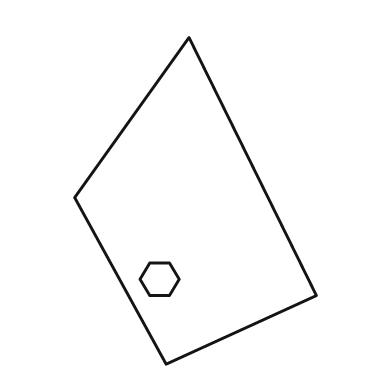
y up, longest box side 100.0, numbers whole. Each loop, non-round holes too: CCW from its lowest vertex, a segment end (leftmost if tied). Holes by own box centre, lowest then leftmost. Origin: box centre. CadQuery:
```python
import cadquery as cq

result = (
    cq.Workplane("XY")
    .moveTo(-9.0, -50.0)
    .lineTo(37.0, -29.0)
    .lineTo(-2.0, 50.0)
    .lineTo(-37.0, 1.0)
    .close()
    .moveTo(-14.0, -29.0)
    .lineTo(-8.0, -29.0)
    .lineTo(-5.0, -24.0)
    .lineTo(-8.0, -19.0)
    .lineTo(-14.0, -19.0)
    .lineTo(-17.0, -24.0)
    .close()
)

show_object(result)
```